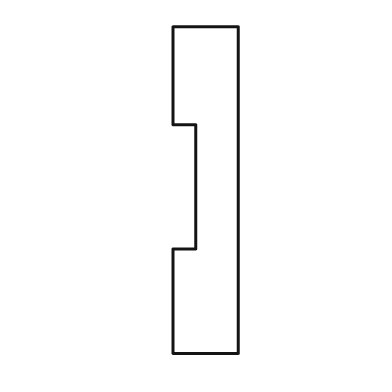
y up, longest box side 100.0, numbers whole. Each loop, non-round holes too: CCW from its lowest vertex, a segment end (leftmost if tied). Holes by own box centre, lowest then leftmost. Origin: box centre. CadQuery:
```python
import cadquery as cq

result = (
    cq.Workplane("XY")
    .moveTo(-10.0, -50.0)
    .lineTo(10.0, -50.0)
    .lineTo(10.0, 50.0)
    .lineTo(-10.0, 50.0)
    .lineTo(-10.0, 20.0)
    .lineTo(-3.0, 20.0)
    .lineTo(-3.0, -18.0)
    .lineTo(-10.0, -18.0)
    .close()
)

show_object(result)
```